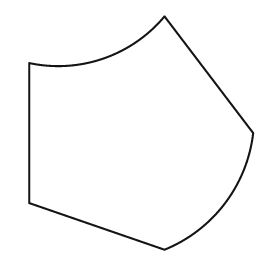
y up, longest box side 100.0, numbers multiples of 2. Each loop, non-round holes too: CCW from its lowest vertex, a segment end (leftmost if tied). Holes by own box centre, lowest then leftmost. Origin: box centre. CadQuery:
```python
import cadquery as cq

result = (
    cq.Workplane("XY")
    .moveTo(10.0, -50.0)
    .threePointArc((36.0, -30.0), (48.0, 0.0))
    .lineTo(10.0, 50.0)
    .threePointArc((-16.0, 32.0), (-48.0, 30.0))
    .lineTo(-48.0, -30.0)
    .close()
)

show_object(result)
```